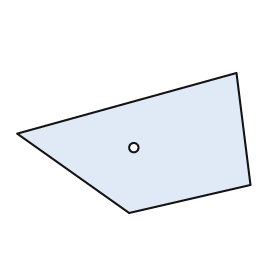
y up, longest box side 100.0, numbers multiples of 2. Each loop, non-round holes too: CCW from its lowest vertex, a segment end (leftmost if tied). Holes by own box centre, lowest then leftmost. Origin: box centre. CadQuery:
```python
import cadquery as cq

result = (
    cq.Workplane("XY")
    .moveTo(-2.0, -30.0)
    .lineTo(50.0, -18.0)
    .lineTo(44.0, 30.0)
    .lineTo(-50.0, 4.0)
    .close()
    .moveTo(0.0, -2.0)
    .circle(2.0)
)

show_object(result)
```